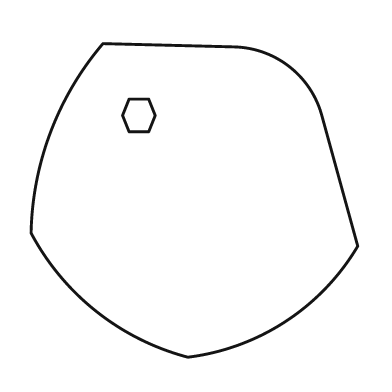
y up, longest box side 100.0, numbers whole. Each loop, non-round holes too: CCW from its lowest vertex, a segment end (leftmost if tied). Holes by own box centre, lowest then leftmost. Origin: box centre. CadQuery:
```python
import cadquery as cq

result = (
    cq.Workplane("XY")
    .moveTo(-2.0, -48.0)
    .threePointArc((28.0, -37.0), (50.0, -14.0))
    .lineTo(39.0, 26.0)
    .threePointArc((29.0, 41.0), (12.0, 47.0))
    .lineTo(-28.0, 48.0)
    .threePointArc((-44.0, 21.0), (-50.0, -10.0))
    .threePointArc((-30.0, -34.0), (-2.0, -48.0))
    .close()
    .moveTo(-20.0, 21.0)
    .lineTo(-14.0, 21.0)
    .lineTo(-12.0, 26.0)
    .lineTo(-14.0, 31.0)
    .lineTo(-20.0, 31.0)
    .lineTo(-22.0, 26.0)
    .close()
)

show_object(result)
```